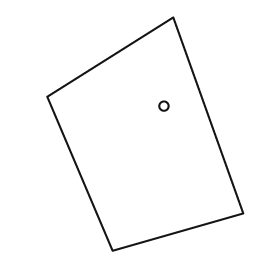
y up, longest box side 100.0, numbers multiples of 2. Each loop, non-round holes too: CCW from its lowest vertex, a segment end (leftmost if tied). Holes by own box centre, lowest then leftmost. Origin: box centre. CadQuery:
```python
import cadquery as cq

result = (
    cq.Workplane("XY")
    .moveTo(-14.0, -50.0)
    .lineTo(42.0, -34.0)
    .lineTo(12.0, 50.0)
    .lineTo(-42.0, 16.0)
    .close()
    .moveTo(8.0, 12.0)
    .circle(2.0)
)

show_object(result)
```